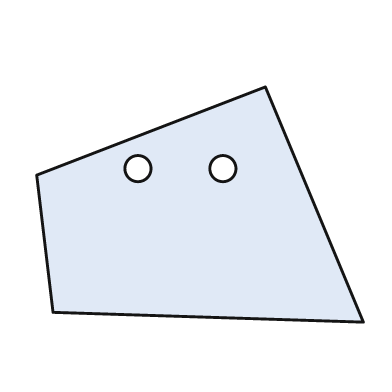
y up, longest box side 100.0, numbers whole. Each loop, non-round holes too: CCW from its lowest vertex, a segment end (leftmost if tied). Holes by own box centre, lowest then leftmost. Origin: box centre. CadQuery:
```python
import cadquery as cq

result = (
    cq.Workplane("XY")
    .moveTo(50.0, -36.0)
    .lineTo(20.0, 36.0)
    .lineTo(-50.0, 9.0)
    .lineTo(-45.0, -33.0)
    .close()
    .moveTo(-19.0, 11.0)
    .circle(4.0)
    .moveTo(7.0, 11.0)
    .circle(4.0)
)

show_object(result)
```